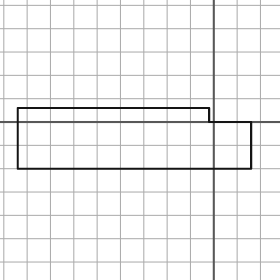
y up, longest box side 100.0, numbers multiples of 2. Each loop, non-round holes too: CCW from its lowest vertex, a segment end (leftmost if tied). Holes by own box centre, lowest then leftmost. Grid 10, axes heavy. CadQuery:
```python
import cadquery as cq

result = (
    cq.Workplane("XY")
    .moveTo(-84.0, -20.0)
    .lineTo(16.0, -20.0)
    .lineTo(16.0, 0.0)
    .lineTo(-2.0, 0.0)
    .lineTo(-2.0, 6.0)
    .lineTo(-84.0, 6.0)
    .close()
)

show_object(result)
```